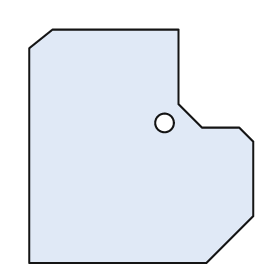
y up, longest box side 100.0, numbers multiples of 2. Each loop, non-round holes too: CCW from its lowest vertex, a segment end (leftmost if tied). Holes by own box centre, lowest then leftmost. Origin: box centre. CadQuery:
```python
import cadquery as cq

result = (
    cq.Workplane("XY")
    .moveTo(-48.0, -50.0)
    .lineTo(28.0, -50.0)
    .lineTo(48.0, -30.0)
    .lineTo(48.0, 2.0)
    .lineTo(42.0, 8.0)
    .lineTo(26.0, 8.0)
    .lineTo(16.0, 18.0)
    .lineTo(16.0, 50.0)
    .lineTo(-38.0, 50.0)
    .lineTo(-48.0, 42.0)
    .close()
    .moveTo(10.0, 10.0)
    .circle(4.0)
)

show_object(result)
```